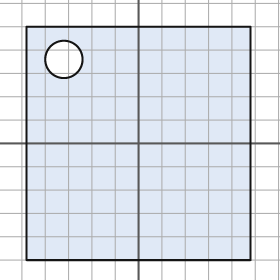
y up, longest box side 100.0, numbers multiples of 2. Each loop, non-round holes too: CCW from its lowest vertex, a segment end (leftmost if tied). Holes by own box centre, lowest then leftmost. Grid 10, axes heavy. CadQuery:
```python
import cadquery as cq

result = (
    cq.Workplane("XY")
    .moveTo(-48.0, -50.0)
    .lineTo(48.0, -50.0)
    .lineTo(48.0, 50.0)
    .lineTo(-48.0, 50.0)
    .close()
    .moveTo(-32.0, 36.0)
    .circle(8.0)
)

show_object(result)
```